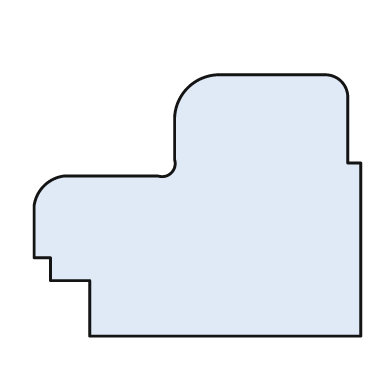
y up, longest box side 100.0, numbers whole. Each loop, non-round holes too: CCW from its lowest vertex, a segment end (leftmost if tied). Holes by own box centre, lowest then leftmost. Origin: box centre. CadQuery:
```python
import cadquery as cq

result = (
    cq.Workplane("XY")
    .moveTo(-33.0, -40.0)
    .lineTo(50.0, -40.0)
    .lineTo(50.0, 13.0)
    .lineTo(46.0, 13.0)
    .lineTo(46.0, 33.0)
    .threePointArc((44.0, 38.0), (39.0, 40.0))
    .lineTo(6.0, 40.0)
    .threePointArc((-3.0, 36.0), (-7.0, 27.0))
    .lineTo(-7.0, 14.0)
    .threePointArc((-8.0, 10.0), (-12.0, 9.0))
    .lineTo(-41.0, 9.0)
    .threePointArc((-47.0, 6.0), (-50.0, 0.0))
    .lineTo(-50.0, -16.0)
    .lineTo(-45.0, -16.0)
    .lineTo(-45.0, -23.0)
    .lineTo(-33.0, -23.0)
    .close()
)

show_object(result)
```